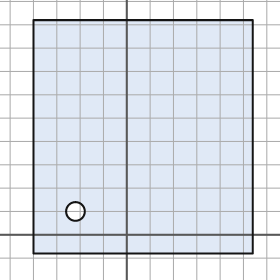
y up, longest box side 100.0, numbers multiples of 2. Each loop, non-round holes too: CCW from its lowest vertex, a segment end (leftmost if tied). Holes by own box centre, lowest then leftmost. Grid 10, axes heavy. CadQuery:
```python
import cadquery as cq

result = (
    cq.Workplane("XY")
    .moveTo(-40.0, -8.0)
    .lineTo(54.0, -8.0)
    .lineTo(54.0, 92.0)
    .lineTo(-40.0, 92.0)
    .close()
    .moveTo(-22.0, 10.0)
    .circle(4.0)
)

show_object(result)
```